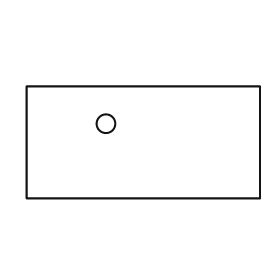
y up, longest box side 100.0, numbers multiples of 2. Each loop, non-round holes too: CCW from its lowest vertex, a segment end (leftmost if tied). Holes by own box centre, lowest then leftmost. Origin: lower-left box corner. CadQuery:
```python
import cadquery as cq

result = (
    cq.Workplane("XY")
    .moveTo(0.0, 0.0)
    .lineTo(100.0, 0.0)
    .lineTo(100.0, 48.0)
    .lineTo(0.0, 48.0)
    .close()
    .moveTo(34.0, 32.0)
    .circle(4.0)
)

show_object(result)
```